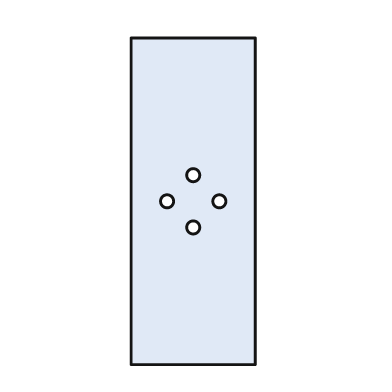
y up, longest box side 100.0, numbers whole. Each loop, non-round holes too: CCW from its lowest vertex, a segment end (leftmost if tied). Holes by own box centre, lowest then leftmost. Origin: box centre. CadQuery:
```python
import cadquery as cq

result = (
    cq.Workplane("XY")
    .moveTo(-19.0, -50.0)
    .lineTo(19.0, -50.0)
    .lineTo(19.0, 50.0)
    .lineTo(-19.0, 50.0)
    .close()
    .moveTo(0.0, -8.0)
    .circle(2.0)
    .moveTo(-8.0, 0.0)
    .circle(2.0)
    .moveTo(8.0, 0.0)
    .circle(2.0)
    .moveTo(0.0, 8.0)
    .circle(2.0)
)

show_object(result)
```